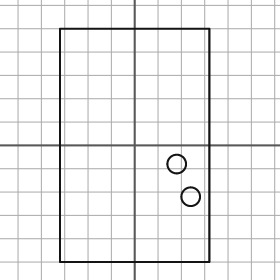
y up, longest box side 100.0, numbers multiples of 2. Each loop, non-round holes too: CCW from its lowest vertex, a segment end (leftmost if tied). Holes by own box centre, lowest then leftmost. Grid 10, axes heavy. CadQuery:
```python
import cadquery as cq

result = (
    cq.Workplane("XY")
    .moveTo(-32.0, -50.0)
    .lineTo(32.0, -50.0)
    .lineTo(32.0, 50.0)
    .lineTo(-32.0, 50.0)
    .close()
    .moveTo(24.0, -22.0)
    .circle(4.0)
    .moveTo(18.0, -8.0)
    .circle(4.0)
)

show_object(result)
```